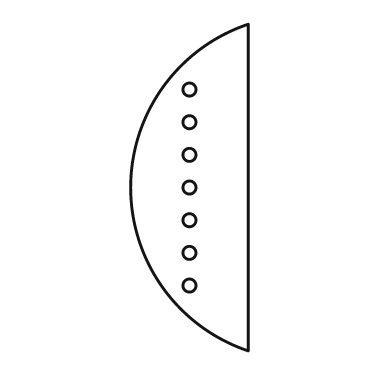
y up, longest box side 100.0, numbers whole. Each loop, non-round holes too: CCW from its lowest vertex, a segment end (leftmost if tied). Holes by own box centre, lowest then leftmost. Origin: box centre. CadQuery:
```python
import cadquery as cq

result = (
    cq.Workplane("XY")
    .moveTo(18.0, -50.0)
    .lineTo(18.0, 50.0)
    .threePointArc((-18.0, 0.0), (18.0, -50.0))
    .close()
    .moveTo(0.0, -30.0)
    .circle(2.0)
    .moveTo(0.0, -20.0)
    .circle(2.0)
    .moveTo(0.0, -10.0)
    .circle(2.0)
    .moveTo(0.0, 0.0)
    .circle(2.0)
    .moveTo(0.0, 10.0)
    .circle(2.0)
    .moveTo(0.0, 20.0)
    .circle(2.0)
    .moveTo(0.0, 30.0)
    .circle(2.0)
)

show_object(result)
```